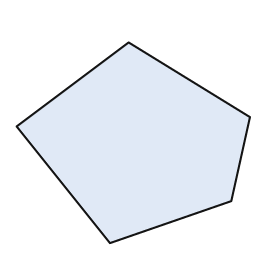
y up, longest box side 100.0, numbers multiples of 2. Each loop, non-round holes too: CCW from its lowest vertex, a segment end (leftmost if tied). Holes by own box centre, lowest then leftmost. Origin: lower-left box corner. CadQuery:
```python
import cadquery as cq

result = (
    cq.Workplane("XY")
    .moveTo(40.0, 0.0)
    .lineTo(92.0, 18.0)
    .lineTo(100.0, 54.0)
    .lineTo(48.0, 86.0)
    .lineTo(0.0, 50.0)
    .close()
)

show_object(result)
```